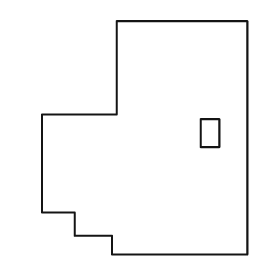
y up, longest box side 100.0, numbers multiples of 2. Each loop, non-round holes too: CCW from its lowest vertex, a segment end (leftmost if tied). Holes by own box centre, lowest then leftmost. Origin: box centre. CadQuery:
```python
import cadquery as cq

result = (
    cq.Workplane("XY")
    .moveTo(-14.0, -50.0)
    .lineTo(44.0, -50.0)
    .lineTo(44.0, 50.0)
    .lineTo(-12.0, 50.0)
    .lineTo(-12.0, 10.0)
    .lineTo(-44.0, 10.0)
    .lineTo(-44.0, -32.0)
    .lineTo(-30.0, -32.0)
    .lineTo(-30.0, -42.0)
    .lineTo(-14.0, -42.0)
    .close()
    .moveTo(24.0, -4.0)
    .lineTo(32.0, -4.0)
    .lineTo(32.0, 8.0)
    .lineTo(24.0, 8.0)
    .close()
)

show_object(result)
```